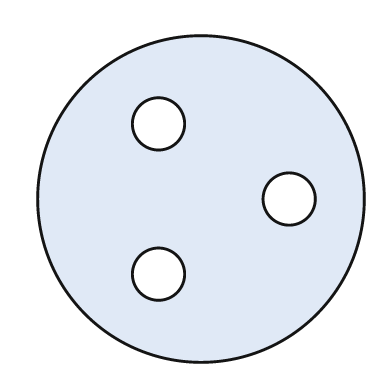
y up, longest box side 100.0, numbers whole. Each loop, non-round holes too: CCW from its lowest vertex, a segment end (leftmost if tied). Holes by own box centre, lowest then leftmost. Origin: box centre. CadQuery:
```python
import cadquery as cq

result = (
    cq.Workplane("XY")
    .moveTo(0.0, 0.0)
    .circle(50.0)
    .moveTo(-13.0, -23.0)
    .circle(8.0)
    .moveTo(27.0, 0.0)
    .circle(8.0)
    .moveTo(-13.0, 23.0)
    .circle(8.0)
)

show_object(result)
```